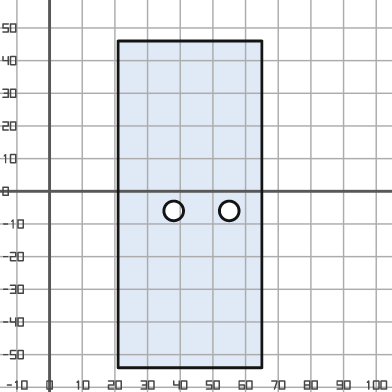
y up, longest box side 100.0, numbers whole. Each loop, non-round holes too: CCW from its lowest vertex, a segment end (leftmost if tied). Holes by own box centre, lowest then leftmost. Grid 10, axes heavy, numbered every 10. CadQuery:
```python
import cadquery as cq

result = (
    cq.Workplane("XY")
    .moveTo(21.0, -54.0)
    .lineTo(65.0, -54.0)
    .lineTo(65.0, 46.0)
    .lineTo(21.0, 46.0)
    .close()
    .moveTo(38.0, -6.0)
    .circle(3.0)
    .moveTo(55.0, -6.0)
    .circle(3.0)
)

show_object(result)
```